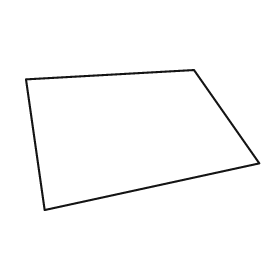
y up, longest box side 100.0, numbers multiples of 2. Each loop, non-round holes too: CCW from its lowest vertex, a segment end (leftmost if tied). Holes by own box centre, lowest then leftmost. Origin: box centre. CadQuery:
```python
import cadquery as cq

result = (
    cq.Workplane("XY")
    .moveTo(-42.0, -30.0)
    .lineTo(50.0, -10.0)
    .lineTo(22.0, 30.0)
    .lineTo(-50.0, 26.0)
    .close()
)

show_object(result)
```